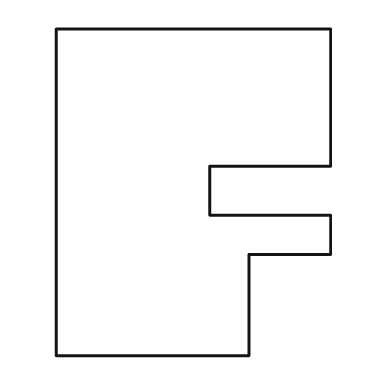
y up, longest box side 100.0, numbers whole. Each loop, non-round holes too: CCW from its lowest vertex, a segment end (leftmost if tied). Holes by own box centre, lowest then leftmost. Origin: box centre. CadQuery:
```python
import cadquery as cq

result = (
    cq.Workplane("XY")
    .moveTo(-42.0, -50.0)
    .lineTo(17.0, -50.0)
    .lineTo(17.0, -19.0)
    .lineTo(42.0, -19.0)
    .lineTo(42.0, -7.0)
    .lineTo(5.0, -7.0)
    .lineTo(5.0, 8.0)
    .lineTo(42.0, 8.0)
    .lineTo(42.0, 50.0)
    .lineTo(-42.0, 50.0)
    .close()
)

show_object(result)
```